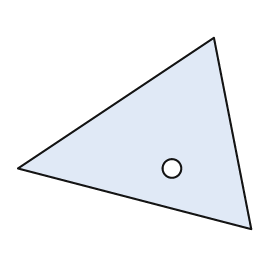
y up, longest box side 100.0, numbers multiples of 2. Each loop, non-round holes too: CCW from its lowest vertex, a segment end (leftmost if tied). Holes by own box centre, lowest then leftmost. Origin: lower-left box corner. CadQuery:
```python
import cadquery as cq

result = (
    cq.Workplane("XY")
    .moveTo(100.0, 0.0)
    .lineTo(84.0, 82.0)
    .lineTo(0.0, 26.0)
    .close()
    .moveTo(66.0, 26.0)
    .circle(4.0)
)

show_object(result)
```